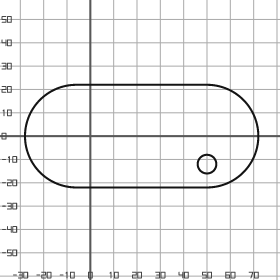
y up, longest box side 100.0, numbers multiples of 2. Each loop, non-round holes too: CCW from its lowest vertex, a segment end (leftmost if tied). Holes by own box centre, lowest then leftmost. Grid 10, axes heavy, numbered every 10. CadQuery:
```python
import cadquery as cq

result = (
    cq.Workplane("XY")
    .moveTo(-6.0, -22.0)
    .lineTo(50.0, -22.0)
    .threePointArc((72.0, 0.0), (50.0, 22.0))
    .lineTo(-6.0, 22.0)
    .threePointArc((-28.0, 0.0), (-6.0, -22.0))
    .close()
    .moveTo(50.0, -12.0)
    .circle(4.0)
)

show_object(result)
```